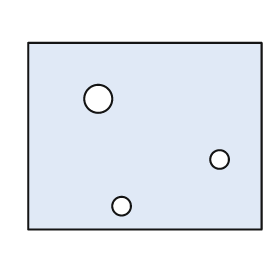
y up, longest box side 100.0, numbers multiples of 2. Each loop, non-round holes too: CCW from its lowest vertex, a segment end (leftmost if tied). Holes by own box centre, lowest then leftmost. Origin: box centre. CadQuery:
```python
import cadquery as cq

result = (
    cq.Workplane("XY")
    .moveTo(-50.0, -40.0)
    .lineTo(50.0, -40.0)
    .lineTo(50.0, 40.0)
    .lineTo(-50.0, 40.0)
    .close()
    .moveTo(-10.0, -30.0)
    .circle(4.0)
    .moveTo(32.0, -10.0)
    .circle(4.0)
    .moveTo(-20.0, 16.0)
    .circle(6.0)
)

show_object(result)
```